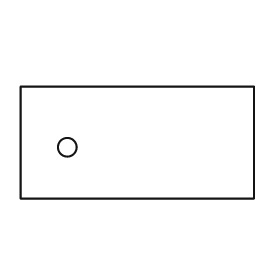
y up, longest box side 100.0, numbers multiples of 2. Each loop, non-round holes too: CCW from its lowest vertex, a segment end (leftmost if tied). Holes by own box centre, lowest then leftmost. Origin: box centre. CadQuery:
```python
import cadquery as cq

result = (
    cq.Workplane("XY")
    .moveTo(-50.0, -24.0)
    .lineTo(50.0, -24.0)
    .lineTo(50.0, 24.0)
    .lineTo(-50.0, 24.0)
    .close()
    .moveTo(-30.0, -2.0)
    .circle(4.0)
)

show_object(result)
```